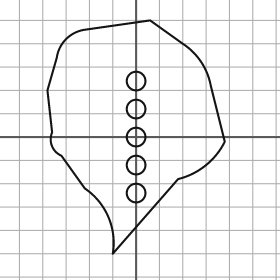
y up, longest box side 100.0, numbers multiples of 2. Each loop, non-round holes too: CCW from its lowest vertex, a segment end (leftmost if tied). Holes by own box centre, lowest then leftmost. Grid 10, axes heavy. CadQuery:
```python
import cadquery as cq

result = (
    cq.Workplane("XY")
    .moveTo(-10.0, -50.0)
    .lineTo(18.0, -18.0)
    .threePointArc((30.0, -12.0), (38.0, -2.0))
    .lineTo(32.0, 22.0)
    .threePointArc((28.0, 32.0), (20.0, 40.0))
    .lineTo(6.0, 50.0)
    .lineTo(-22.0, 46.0)
    .threePointArc((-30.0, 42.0), (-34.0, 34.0))
    .lineTo(-38.0, 20.0)
    .lineTo(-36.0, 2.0)
    .threePointArc((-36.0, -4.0), (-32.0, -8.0))
    .lineTo(-22.0, -22.0)
    .threePointArc((-12.0, -34.0), (-10.0, -50.0))
    .close()
    .moveTo(0.0, -24.0)
    .circle(4.0)
    .moveTo(0.0, -12.0)
    .circle(4.0)
    .moveTo(0.0, 0.0)
    .circle(4.0)
    .moveTo(0.0, 12.0)
    .circle(4.0)
    .moveTo(0.0, 24.0)
    .circle(4.0)
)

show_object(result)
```